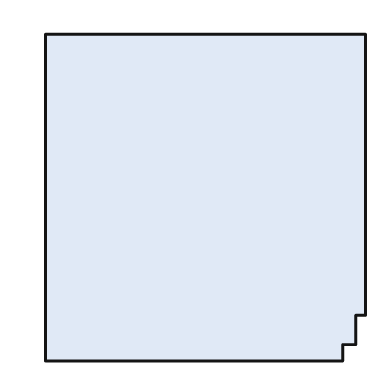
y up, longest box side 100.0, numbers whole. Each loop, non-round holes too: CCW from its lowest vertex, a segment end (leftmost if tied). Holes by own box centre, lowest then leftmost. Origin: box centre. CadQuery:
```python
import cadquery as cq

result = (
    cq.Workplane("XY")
    .moveTo(-49.0, -50.0)
    .lineTo(42.0, -50.0)
    .lineTo(42.0, -45.0)
    .lineTo(46.0, -45.0)
    .lineTo(46.0, -36.0)
    .lineTo(49.0, -36.0)
    .lineTo(49.0, 50.0)
    .lineTo(-49.0, 50.0)
    .close()
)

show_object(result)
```